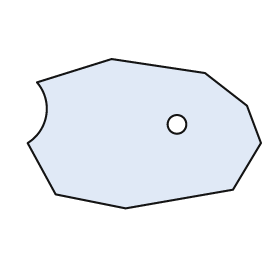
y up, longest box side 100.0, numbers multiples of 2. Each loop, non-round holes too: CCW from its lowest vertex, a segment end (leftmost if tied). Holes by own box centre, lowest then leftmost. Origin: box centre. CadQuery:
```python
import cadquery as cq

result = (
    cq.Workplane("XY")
    .moveTo(-8.0, -32.0)
    .lineTo(38.0, -24.0)
    .lineTo(50.0, -4.0)
    .lineTo(44.0, 12.0)
    .lineTo(26.0, 26.0)
    .lineTo(-14.0, 32.0)
    .lineTo(-46.0, 22.0)
    .threePointArc((-42.0, 8.0), (-50.0, -4.0))
    .lineTo(-38.0, -26.0)
    .close()
    .moveTo(14.0, 4.0)
    .circle(4.0)
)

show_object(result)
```